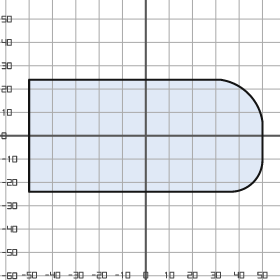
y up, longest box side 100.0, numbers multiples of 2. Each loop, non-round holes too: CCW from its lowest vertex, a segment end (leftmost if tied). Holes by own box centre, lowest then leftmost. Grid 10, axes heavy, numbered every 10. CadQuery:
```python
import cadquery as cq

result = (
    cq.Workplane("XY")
    .moveTo(-50.0, -24.0)
    .lineTo(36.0, -24.0)
    .threePointArc((46.0, -20.0), (50.0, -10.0))
    .lineTo(50.0, 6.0)
    .threePointArc((44.0, 18.0), (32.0, 24.0))
    .lineTo(-50.0, 24.0)
    .close()
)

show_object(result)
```